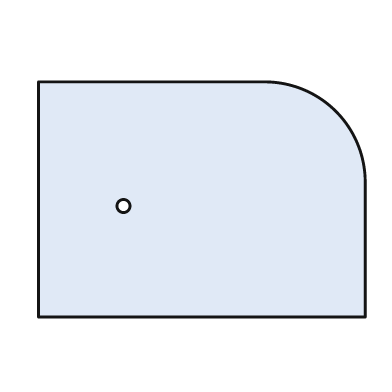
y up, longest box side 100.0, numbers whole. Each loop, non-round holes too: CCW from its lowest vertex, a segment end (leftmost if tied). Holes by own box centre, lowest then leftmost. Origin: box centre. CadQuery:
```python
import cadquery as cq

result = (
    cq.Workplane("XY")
    .moveTo(-50.0, -36.0)
    .lineTo(50.0, -36.0)
    .lineTo(50.0, 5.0)
    .threePointArc((41.0, 27.0), (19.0, 36.0))
    .lineTo(-50.0, 36.0)
    .close()
    .moveTo(-24.0, -2.0)
    .circle(2.0)
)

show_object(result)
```